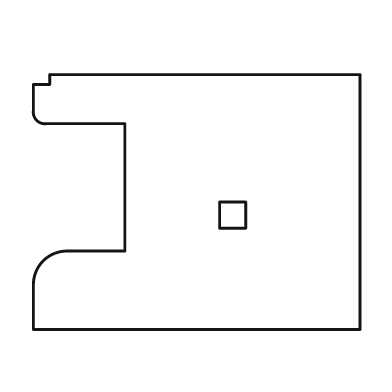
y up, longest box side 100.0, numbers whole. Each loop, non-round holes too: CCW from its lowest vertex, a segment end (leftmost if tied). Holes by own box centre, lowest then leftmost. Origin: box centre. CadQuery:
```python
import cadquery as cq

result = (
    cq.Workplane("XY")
    .moveTo(-50.0, -39.0)
    .lineTo(50.0, -39.0)
    .lineTo(50.0, 39.0)
    .lineTo(-45.0, 39.0)
    .lineTo(-45.0, 36.0)
    .lineTo(-50.0, 36.0)
    .lineTo(-50.0, 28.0)
    .threePointArc((-49.0, 25.0), (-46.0, 24.0))
    .lineTo(-22.0, 24.0)
    .lineTo(-22.0, -15.0)
    .lineTo(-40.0, -15.0)
    .threePointArc((-47.0, -18.0), (-50.0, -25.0))
    .close()
    .moveTo(7.0, -8.0)
    .lineTo(15.0, -8.0)
    .lineTo(15.0, 0.0)
    .lineTo(7.0, 0.0)
    .close()
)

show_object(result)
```